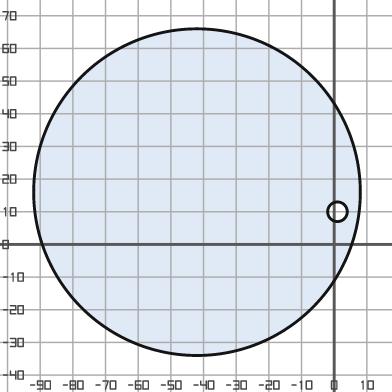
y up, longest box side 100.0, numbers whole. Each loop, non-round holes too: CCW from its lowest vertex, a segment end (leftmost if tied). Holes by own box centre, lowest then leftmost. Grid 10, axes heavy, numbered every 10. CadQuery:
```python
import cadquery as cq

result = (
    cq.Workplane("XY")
    .moveTo(-42.0, 16.0)
    .circle(50.0)
    .moveTo(1.0, 10.0)
    .circle(3.0)
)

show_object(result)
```